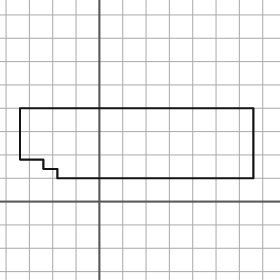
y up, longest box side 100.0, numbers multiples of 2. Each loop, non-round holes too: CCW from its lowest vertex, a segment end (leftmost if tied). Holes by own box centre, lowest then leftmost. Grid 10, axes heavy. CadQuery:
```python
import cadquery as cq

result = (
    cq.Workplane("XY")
    .moveTo(-18.0, 10.0)
    .lineTo(66.0, 10.0)
    .lineTo(66.0, 40.0)
    .lineTo(-34.0, 40.0)
    .lineTo(-34.0, 18.0)
    .lineTo(-24.0, 18.0)
    .lineTo(-24.0, 14.0)
    .lineTo(-18.0, 14.0)
    .close()
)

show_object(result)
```